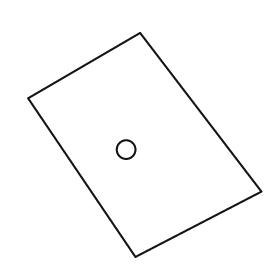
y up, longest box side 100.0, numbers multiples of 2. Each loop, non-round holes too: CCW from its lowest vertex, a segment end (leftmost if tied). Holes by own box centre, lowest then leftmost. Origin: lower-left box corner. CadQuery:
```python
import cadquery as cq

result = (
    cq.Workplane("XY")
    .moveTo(46.0, 0.0)
    .lineTo(100.0, 28.0)
    .lineTo(48.0, 96.0)
    .lineTo(0.0, 68.0)
    .close()
    .moveTo(42.0, 46.0)
    .circle(4.0)
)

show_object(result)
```